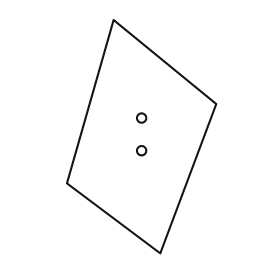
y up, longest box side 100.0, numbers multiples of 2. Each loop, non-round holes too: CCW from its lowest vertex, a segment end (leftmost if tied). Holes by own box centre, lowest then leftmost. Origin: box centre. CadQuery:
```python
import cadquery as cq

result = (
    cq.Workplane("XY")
    .moveTo(8.0, -50.0)
    .lineTo(32.0, 14.0)
    .lineTo(-12.0, 50.0)
    .lineTo(-32.0, -20.0)
    .close()
    .moveTo(0.0, -6.0)
    .circle(2.0)
    .moveTo(0.0, 8.0)
    .circle(2.0)
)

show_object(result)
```